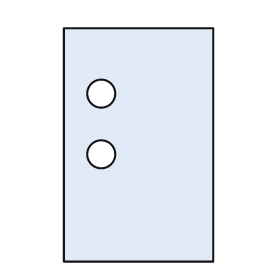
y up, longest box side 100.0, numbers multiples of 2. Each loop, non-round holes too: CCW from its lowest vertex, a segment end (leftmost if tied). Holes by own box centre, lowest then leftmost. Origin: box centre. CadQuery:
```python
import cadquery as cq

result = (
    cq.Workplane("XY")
    .moveTo(-32.0, -50.0)
    .lineTo(32.0, -50.0)
    .lineTo(32.0, 50.0)
    .lineTo(-32.0, 50.0)
    .close()
    .moveTo(-16.0, -4.0)
    .circle(6.0)
    .moveTo(-16.0, 22.0)
    .circle(6.0)
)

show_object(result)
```